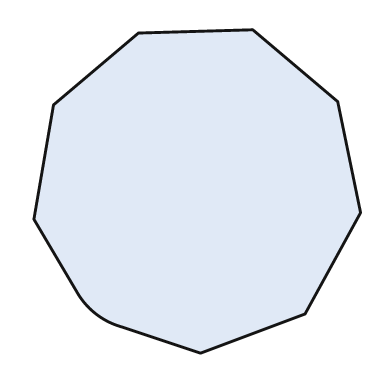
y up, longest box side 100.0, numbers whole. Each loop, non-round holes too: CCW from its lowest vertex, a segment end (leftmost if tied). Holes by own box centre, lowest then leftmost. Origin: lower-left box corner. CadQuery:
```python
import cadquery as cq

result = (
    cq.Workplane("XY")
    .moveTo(51.0, 0.0)
    .lineTo(83.0, 12.0)
    .lineTo(100.0, 43.0)
    .lineTo(93.0, 77.0)
    .lineTo(67.0, 99.0)
    .lineTo(32.0, 98.0)
    .lineTo(6.0, 76.0)
    .lineTo(0.0, 41.0)
    .lineTo(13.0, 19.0)
    .threePointArc((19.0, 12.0), (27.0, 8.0))
    .close()
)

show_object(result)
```